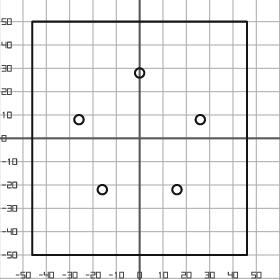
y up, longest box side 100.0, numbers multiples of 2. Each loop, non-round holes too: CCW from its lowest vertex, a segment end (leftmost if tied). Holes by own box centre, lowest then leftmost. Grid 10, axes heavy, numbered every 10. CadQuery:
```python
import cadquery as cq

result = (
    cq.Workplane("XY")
    .moveTo(-46.0, -50.0)
    .lineTo(46.0, -50.0)
    .lineTo(46.0, 50.0)
    .lineTo(-46.0, 50.0)
    .close()
    .moveTo(-16.0, -22.0)
    .circle(2.0)
    .moveTo(16.0, -22.0)
    .circle(2.0)
    .moveTo(-26.0, 8.0)
    .circle(2.0)
    .moveTo(26.0, 8.0)
    .circle(2.0)
    .moveTo(0.0, 28.0)
    .circle(2.0)
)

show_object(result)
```